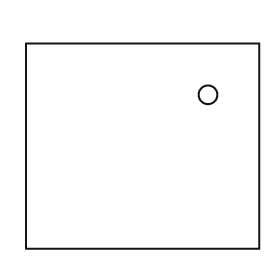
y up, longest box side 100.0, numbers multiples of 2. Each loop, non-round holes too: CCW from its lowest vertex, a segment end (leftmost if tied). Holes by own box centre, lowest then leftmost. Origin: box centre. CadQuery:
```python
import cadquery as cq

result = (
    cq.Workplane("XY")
    .moveTo(-50.0, -44.0)
    .lineTo(50.0, -44.0)
    .lineTo(50.0, 44.0)
    .lineTo(-50.0, 44.0)
    .close()
    .moveTo(28.0, 22.0)
    .circle(4.0)
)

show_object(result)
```